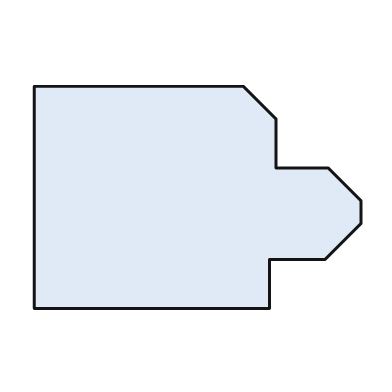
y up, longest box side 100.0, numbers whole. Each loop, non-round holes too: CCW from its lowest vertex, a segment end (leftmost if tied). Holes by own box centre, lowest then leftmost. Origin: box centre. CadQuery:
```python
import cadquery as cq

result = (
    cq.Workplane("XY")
    .moveTo(-50.0, -34.0)
    .lineTo(22.0, -34.0)
    .lineTo(22.0, -19.0)
    .lineTo(39.0, -19.0)
    .lineTo(50.0, -8.0)
    .lineTo(50.0, -1.0)
    .lineTo(40.0, 9.0)
    .lineTo(24.0, 9.0)
    .lineTo(24.0, 24.0)
    .lineTo(14.0, 34.0)
    .lineTo(-50.0, 34.0)
    .close()
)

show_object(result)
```